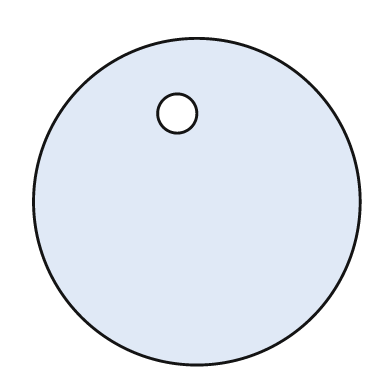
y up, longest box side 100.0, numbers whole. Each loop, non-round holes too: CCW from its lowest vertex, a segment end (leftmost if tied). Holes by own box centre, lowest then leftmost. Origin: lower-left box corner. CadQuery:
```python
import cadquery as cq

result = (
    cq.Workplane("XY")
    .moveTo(50.0, 50.0)
    .circle(50.0)
    .moveTo(44.0, 77.0)
    .circle(6.0)
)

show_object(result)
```